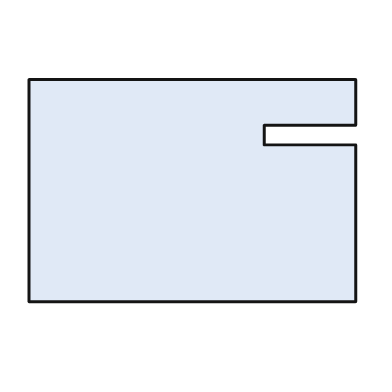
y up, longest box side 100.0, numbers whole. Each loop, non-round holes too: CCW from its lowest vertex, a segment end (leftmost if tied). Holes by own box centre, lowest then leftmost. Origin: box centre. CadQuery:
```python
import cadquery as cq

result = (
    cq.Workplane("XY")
    .moveTo(-50.0, -34.0)
    .lineTo(50.0, -34.0)
    .lineTo(50.0, 14.0)
    .lineTo(22.0, 14.0)
    .lineTo(22.0, 20.0)
    .lineTo(50.0, 20.0)
    .lineTo(50.0, 34.0)
    .lineTo(-50.0, 34.0)
    .close()
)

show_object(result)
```